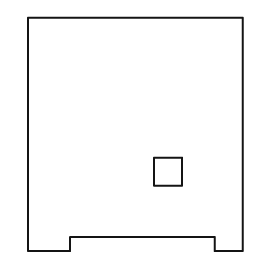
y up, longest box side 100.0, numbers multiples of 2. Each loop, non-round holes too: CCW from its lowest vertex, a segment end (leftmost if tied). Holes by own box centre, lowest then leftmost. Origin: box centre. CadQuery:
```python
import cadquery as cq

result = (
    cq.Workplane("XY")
    .moveTo(-46.0, -50.0)
    .lineTo(-28.0, -50.0)
    .lineTo(-28.0, -44.0)
    .lineTo(34.0, -44.0)
    .lineTo(34.0, -50.0)
    .lineTo(46.0, -50.0)
    .lineTo(46.0, 50.0)
    .lineTo(-46.0, 50.0)
    .close()
    .moveTo(8.0, -22.0)
    .lineTo(20.0, -22.0)
    .lineTo(20.0, -10.0)
    .lineTo(8.0, -10.0)
    .close()
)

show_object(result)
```